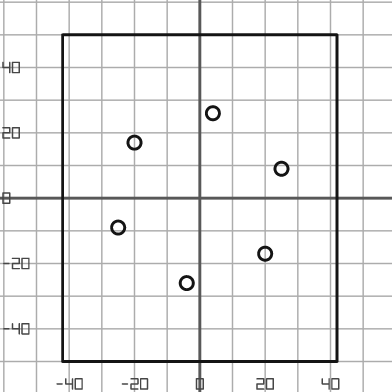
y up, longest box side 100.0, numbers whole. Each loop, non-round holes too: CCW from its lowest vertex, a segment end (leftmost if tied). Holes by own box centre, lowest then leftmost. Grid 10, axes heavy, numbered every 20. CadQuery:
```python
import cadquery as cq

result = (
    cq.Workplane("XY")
    .moveTo(-42.0, -50.0)
    .lineTo(42.0, -50.0)
    .lineTo(42.0, 50.0)
    .lineTo(-42.0, 50.0)
    .close()
    .moveTo(-4.0, -26.0)
    .circle(2.0)
    .moveTo(20.0, -17.0)
    .circle(2.0)
    .moveTo(-25.0, -9.0)
    .circle(2.0)
    .moveTo(25.0, 9.0)
    .circle(2.0)
    .moveTo(-20.0, 17.0)
    .circle(2.0)
    .moveTo(4.0, 26.0)
    .circle(2.0)
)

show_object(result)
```